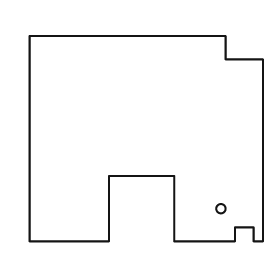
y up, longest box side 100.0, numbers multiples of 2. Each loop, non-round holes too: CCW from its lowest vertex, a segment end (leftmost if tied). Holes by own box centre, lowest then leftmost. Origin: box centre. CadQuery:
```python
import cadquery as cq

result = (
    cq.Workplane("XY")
    .moveTo(-50.0, -44.0)
    .lineTo(-16.0, -44.0)
    .lineTo(-16.0, -16.0)
    .lineTo(12.0, -16.0)
    .lineTo(12.0, -44.0)
    .lineTo(38.0, -44.0)
    .lineTo(38.0, -38.0)
    .lineTo(46.0, -38.0)
    .lineTo(46.0, -44.0)
    .lineTo(50.0, -44.0)
    .lineTo(50.0, 34.0)
    .lineTo(34.0, 34.0)
    .lineTo(34.0, 44.0)
    .lineTo(-50.0, 44.0)
    .close()
    .moveTo(32.0, -30.0)
    .circle(2.0)
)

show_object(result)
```